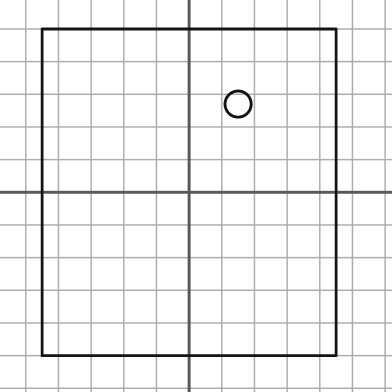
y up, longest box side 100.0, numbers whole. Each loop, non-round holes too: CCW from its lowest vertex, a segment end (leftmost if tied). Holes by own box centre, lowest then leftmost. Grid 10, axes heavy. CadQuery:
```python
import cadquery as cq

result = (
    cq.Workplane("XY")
    .moveTo(-45.0, -50.0)
    .lineTo(45.0, -50.0)
    .lineTo(45.0, 50.0)
    .lineTo(-45.0, 50.0)
    .close()
    .moveTo(15.0, 27.0)
    .circle(4.0)
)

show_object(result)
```